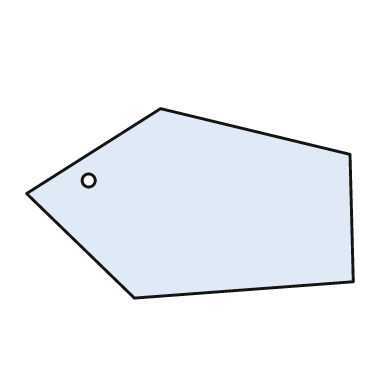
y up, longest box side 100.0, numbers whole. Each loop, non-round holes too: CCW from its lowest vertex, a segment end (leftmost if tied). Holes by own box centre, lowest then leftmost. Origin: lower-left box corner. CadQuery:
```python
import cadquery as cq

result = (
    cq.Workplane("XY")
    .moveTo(33.0, 0.0)
    .lineTo(100.0, 5.0)
    .lineTo(99.0, 44.0)
    .lineTo(41.0, 58.0)
    .lineTo(0.0, 32.0)
    .close()
    .moveTo(19.0, 36.0)
    .circle(2.0)
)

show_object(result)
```